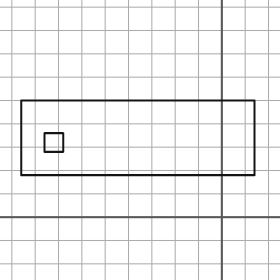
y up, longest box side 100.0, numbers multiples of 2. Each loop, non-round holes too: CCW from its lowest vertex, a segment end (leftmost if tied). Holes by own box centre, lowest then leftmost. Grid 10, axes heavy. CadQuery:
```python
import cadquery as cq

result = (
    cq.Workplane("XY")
    .moveTo(-86.0, 18.0)
    .lineTo(14.0, 18.0)
    .lineTo(14.0, 50.0)
    .lineTo(-86.0, 50.0)
    .close()
    .moveTo(-76.0, 28.0)
    .lineTo(-68.0, 28.0)
    .lineTo(-68.0, 36.0)
    .lineTo(-76.0, 36.0)
    .close()
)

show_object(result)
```